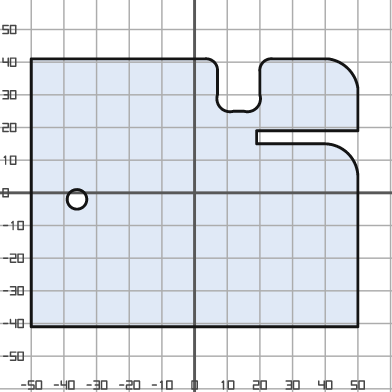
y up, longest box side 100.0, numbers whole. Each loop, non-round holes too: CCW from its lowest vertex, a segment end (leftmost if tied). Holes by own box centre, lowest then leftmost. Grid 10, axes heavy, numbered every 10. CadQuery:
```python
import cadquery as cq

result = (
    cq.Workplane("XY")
    .moveTo(-50.0, -41.0)
    .lineTo(50.0, -41.0)
    .lineTo(50.0, 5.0)
    .threePointArc((47.0, 12.0), (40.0, 15.0))
    .lineTo(19.0, 15.0)
    .lineTo(19.0, 19.0)
    .lineTo(50.0, 19.0)
    .lineTo(50.0, 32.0)
    .threePointArc((47.0, 38.0), (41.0, 41.0))
    .lineTo(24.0, 41.0)
    .threePointArc((21.0, 40.0), (20.0, 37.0))
    .lineTo(20.0, 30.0)
    .threePointArc((19.0, 26.0), (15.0, 25.0))
    .lineTo(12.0, 25.0)
    .threePointArc((8.0, 26.0), (7.0, 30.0))
    .lineTo(7.0, 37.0)
    .threePointArc((6.0, 40.0), (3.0, 41.0))
    .lineTo(-50.0, 41.0)
    .close()
    .moveTo(-36.0, -2.0)
    .circle(3.0)
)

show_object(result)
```